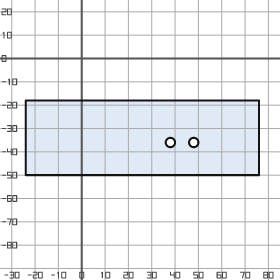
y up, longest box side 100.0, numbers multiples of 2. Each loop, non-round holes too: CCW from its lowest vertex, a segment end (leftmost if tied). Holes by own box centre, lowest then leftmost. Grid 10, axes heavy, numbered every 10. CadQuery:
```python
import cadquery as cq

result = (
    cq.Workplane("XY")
    .moveTo(-24.0, -50.0)
    .lineTo(76.0, -50.0)
    .lineTo(76.0, -18.0)
    .lineTo(-24.0, -18.0)
    .close()
    .moveTo(38.0, -36.0)
    .circle(2.0)
    .moveTo(48.0, -36.0)
    .circle(2.0)
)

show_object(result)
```